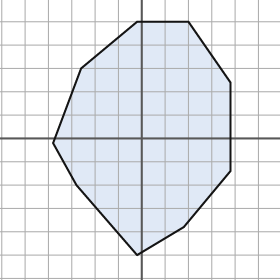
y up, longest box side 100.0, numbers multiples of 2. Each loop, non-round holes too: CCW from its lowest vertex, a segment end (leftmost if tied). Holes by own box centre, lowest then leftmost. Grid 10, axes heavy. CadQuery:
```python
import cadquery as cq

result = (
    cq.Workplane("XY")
    .moveTo(-2.0, -50.0)
    .lineTo(18.0, -38.0)
    .lineTo(38.0, -14.0)
    .lineTo(38.0, 24.0)
    .lineTo(20.0, 50.0)
    .lineTo(-2.0, 50.0)
    .lineTo(-26.0, 30.0)
    .lineTo(-38.0, -2.0)
    .lineTo(-28.0, -20.0)
    .close()
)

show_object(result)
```